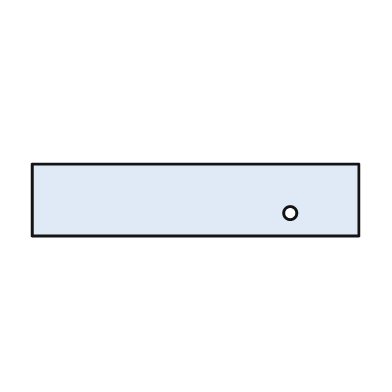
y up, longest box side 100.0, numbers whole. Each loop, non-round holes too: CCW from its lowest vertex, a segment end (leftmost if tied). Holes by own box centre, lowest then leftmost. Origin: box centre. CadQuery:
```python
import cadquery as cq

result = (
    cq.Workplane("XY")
    .moveTo(-50.0, -11.0)
    .lineTo(50.0, -11.0)
    .lineTo(50.0, 11.0)
    .lineTo(-50.0, 11.0)
    .close()
    .moveTo(29.0, -4.0)
    .circle(2.0)
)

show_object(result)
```